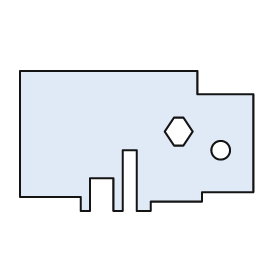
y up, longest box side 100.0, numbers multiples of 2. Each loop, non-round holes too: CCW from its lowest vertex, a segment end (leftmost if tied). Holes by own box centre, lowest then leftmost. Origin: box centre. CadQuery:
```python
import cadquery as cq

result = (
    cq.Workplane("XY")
    .moveTo(-24.0, -30.0)
    .lineTo(-20.0, -30.0)
    .lineTo(-20.0, -16.0)
    .lineTo(-10.0, -16.0)
    .lineTo(-10.0, -30.0)
    .lineTo(-6.0, -30.0)
    .lineTo(-6.0, -4.0)
    .lineTo(0.0, -4.0)
    .lineTo(0.0, -30.0)
    .lineTo(6.0, -30.0)
    .lineTo(6.0, -26.0)
    .lineTo(28.0, -26.0)
    .lineTo(28.0, -22.0)
    .lineTo(50.0, -22.0)
    .lineTo(50.0, 20.0)
    .lineTo(26.0, 20.0)
    .lineTo(26.0, 30.0)
    .lineTo(-50.0, 30.0)
    .lineTo(-50.0, -24.0)
    .lineTo(-24.0, -24.0)
    .close()
    .moveTo(36.0, -4.0)
    .circle(4.0)
    .moveTo(16.0, -2.0)
    .lineTo(20.0, -2.0)
    .lineTo(24.0, 4.0)
    .lineTo(20.0, 10.0)
    .lineTo(16.0, 10.0)
    .lineTo(12.0, 4.0)
    .close()
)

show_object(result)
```